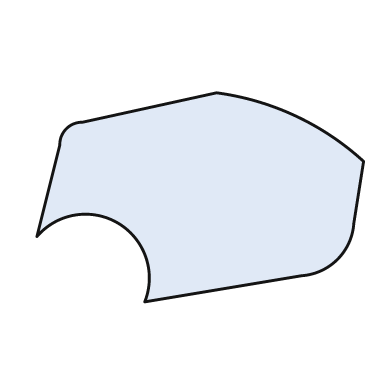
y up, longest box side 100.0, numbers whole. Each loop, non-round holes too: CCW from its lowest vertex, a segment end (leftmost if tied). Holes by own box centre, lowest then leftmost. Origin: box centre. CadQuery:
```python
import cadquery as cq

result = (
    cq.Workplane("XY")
    .moveTo(-17.0, -32.0)
    .lineTo(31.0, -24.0)
    .threePointArc((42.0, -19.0), (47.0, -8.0))
    .lineTo(50.0, 11.0)
    .threePointArc((29.0, 25.0), (5.0, 32.0))
    .lineTo(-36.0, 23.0)
    .threePointArc((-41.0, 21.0), (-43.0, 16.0))
    .lineTo(-50.0, -12.0)
    .threePointArc((-25.0, -8.0), (-17.0, -32.0))
    .close()
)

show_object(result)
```